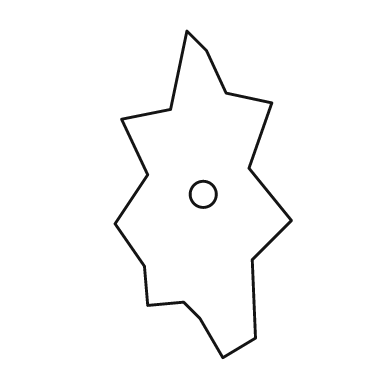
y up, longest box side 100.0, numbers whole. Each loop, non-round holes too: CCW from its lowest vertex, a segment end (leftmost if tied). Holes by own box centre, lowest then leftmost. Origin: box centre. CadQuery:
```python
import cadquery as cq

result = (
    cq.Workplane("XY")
    .moveTo(6.0, -50.0)
    .lineTo(16.0, -44.0)
    .lineTo(15.0, -20.0)
    .lineTo(27.0, -8.0)
    .lineTo(14.0, 8.0)
    .lineTo(21.0, 28.0)
    .lineTo(7.0, 31.0)
    .lineTo(1.0, 44.0)
    .lineTo(-5.0, 50.0)
    .lineTo(-10.0, 26.0)
    .lineTo(-25.0, 23.0)
    .lineTo(-17.0, 6.0)
    .lineTo(-27.0, -9.0)
    .lineTo(-18.0, -22.0)
    .lineTo(-17.0, -34.0)
    .lineTo(-6.0, -33.0)
    .lineTo(-1.0, -38.0)
    .close()
    .moveTo(0.0, 0.0)
    .circle(4.0)
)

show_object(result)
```